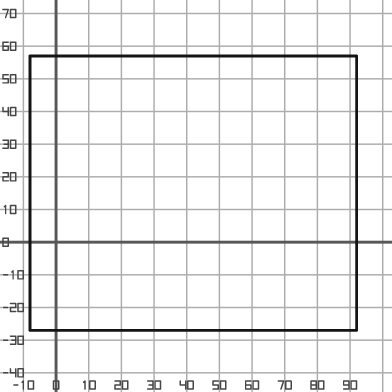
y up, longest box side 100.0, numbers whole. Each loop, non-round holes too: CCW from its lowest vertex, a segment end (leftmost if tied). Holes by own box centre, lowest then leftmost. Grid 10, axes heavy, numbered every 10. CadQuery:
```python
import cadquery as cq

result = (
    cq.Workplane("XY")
    .moveTo(-8.0, -27.0)
    .lineTo(92.0, -27.0)
    .lineTo(92.0, 57.0)
    .lineTo(-8.0, 57.0)
    .close()
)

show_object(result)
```